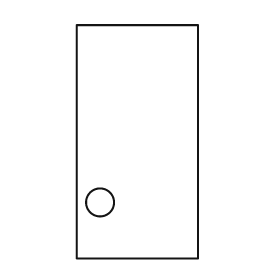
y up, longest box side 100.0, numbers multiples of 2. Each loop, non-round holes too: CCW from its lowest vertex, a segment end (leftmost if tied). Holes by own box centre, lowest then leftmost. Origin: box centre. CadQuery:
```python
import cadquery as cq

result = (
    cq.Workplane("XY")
    .moveTo(-26.0, -50.0)
    .lineTo(26.0, -50.0)
    .lineTo(26.0, 50.0)
    .lineTo(-26.0, 50.0)
    .close()
    .moveTo(-16.0, -26.0)
    .circle(6.0)
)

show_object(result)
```